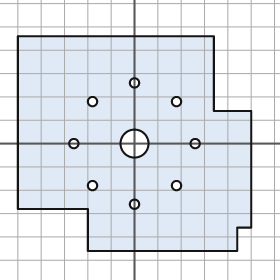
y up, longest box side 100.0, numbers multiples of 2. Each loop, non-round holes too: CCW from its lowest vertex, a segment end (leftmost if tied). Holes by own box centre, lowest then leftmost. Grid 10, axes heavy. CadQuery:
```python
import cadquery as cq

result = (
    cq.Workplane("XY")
    .moveTo(-20.0, -46.0)
    .lineTo(44.0, -46.0)
    .lineTo(44.0, -36.0)
    .lineTo(50.0, -36.0)
    .lineTo(50.0, 14.0)
    .lineTo(34.0, 14.0)
    .lineTo(34.0, 46.0)
    .lineTo(-50.0, 46.0)
    .lineTo(-50.0, -28.0)
    .lineTo(-20.0, -28.0)
    .close()
    .moveTo(0.0, -26.0)
    .circle(2.0)
    .moveTo(-18.0, -18.0)
    .circle(2.0)
    .moveTo(18.0, -18.0)
    .circle(2.0)
    .moveTo(-26.0, 0.0)
    .circle(2.0)
    .moveTo(0.0, 0.0)
    .circle(6.0)
    .moveTo(26.0, 0.0)
    .circle(2.0)
    .moveTo(-18.0, 18.0)
    .circle(2.0)
    .moveTo(18.0, 18.0)
    .circle(2.0)
    .moveTo(0.0, 26.0)
    .circle(2.0)
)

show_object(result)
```